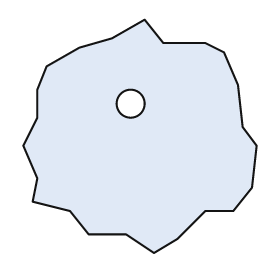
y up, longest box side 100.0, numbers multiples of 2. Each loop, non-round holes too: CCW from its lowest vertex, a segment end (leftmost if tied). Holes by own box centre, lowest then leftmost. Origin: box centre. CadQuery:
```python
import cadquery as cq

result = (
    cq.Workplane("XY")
    .moveTo(6.0, -50.0)
    .lineTo(16.0, -44.0)
    .lineTo(28.0, -32.0)
    .lineTo(40.0, -32.0)
    .lineTo(48.0, -22.0)
    .lineTo(50.0, -4.0)
    .lineTo(44.0, 4.0)
    .lineTo(42.0, 22.0)
    .lineTo(36.0, 36.0)
    .lineTo(28.0, 40.0)
    .lineTo(10.0, 40.0)
    .lineTo(2.0, 50.0)
    .lineTo(-12.0, 42.0)
    .lineTo(-26.0, 38.0)
    .lineTo(-40.0, 30.0)
    .lineTo(-44.0, 20.0)
    .lineTo(-44.0, 8.0)
    .lineTo(-50.0, -4.0)
    .lineTo(-44.0, -18.0)
    .lineTo(-46.0, -28.0)
    .lineTo(-30.0, -32.0)
    .lineTo(-22.0, -42.0)
    .lineTo(-6.0, -42.0)
    .close()
    .moveTo(-4.0, 14.0)
    .circle(6.0)
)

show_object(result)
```